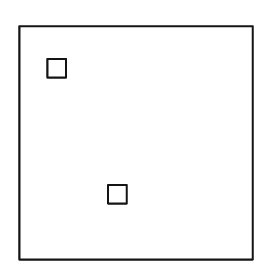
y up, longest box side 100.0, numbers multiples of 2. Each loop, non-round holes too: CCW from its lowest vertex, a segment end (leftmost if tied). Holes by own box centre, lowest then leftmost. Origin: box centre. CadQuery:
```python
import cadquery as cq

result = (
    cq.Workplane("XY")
    .moveTo(-50.0, -50.0)
    .lineTo(50.0, -50.0)
    .lineTo(50.0, 50.0)
    .lineTo(-50.0, 50.0)
    .close()
    .moveTo(-12.0, -26.0)
    .lineTo(-4.0, -26.0)
    .lineTo(-4.0, -18.0)
    .lineTo(-12.0, -18.0)
    .close()
    .moveTo(-38.0, 28.0)
    .lineTo(-30.0, 28.0)
    .lineTo(-30.0, 36.0)
    .lineTo(-38.0, 36.0)
    .close()
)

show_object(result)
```